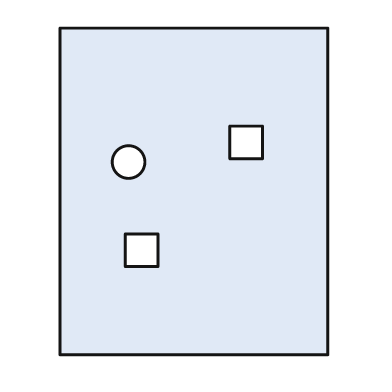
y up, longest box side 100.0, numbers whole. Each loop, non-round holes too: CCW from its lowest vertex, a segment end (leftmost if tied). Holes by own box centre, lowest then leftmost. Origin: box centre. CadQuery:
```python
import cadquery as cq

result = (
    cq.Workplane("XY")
    .moveTo(-41.0, -50.0)
    .lineTo(41.0, -50.0)
    .lineTo(41.0, 50.0)
    .lineTo(-41.0, 50.0)
    .close()
    .moveTo(-21.0, -23.0)
    .lineTo(-11.0, -23.0)
    .lineTo(-11.0, -13.0)
    .lineTo(-21.0, -13.0)
    .close()
    .moveTo(-20.0, 9.0)
    .circle(5.0)
    .moveTo(11.0, 10.0)
    .lineTo(21.0, 10.0)
    .lineTo(21.0, 20.0)
    .lineTo(11.0, 20.0)
    .close()
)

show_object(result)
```